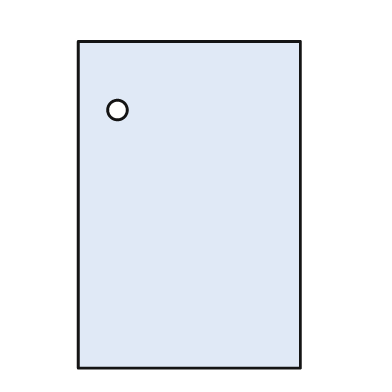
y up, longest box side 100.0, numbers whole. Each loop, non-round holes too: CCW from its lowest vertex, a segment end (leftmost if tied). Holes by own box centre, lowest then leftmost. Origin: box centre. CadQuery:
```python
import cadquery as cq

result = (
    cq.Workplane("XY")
    .moveTo(-34.0, -50.0)
    .lineTo(34.0, -50.0)
    .lineTo(34.0, 50.0)
    .lineTo(-34.0, 50.0)
    .close()
    .moveTo(-22.0, 29.0)
    .circle(3.0)
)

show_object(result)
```